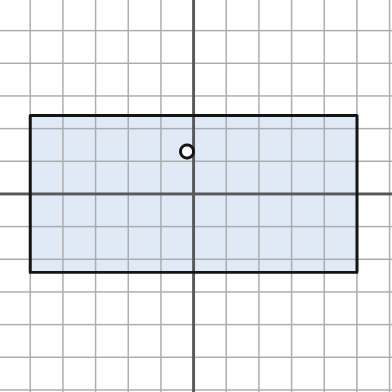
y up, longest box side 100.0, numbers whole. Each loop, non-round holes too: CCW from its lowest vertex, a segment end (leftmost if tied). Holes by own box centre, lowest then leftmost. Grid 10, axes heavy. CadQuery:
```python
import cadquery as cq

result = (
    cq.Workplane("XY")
    .moveTo(-50.0, -24.0)
    .lineTo(50.0, -24.0)
    .lineTo(50.0, 24.0)
    .lineTo(-50.0, 24.0)
    .close()
    .moveTo(-2.0, 13.0)
    .circle(2.0)
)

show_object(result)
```